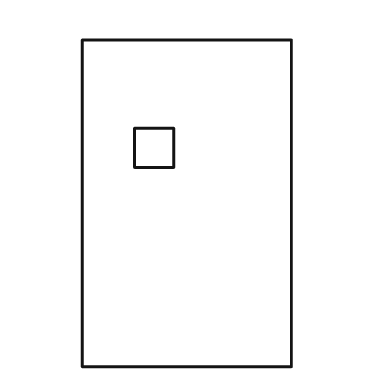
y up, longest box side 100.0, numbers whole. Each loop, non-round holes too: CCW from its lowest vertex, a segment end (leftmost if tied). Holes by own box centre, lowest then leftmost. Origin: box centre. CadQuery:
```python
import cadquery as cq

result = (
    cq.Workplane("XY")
    .moveTo(-32.0, -50.0)
    .lineTo(32.0, -50.0)
    .lineTo(32.0, 50.0)
    .lineTo(-32.0, 50.0)
    .close()
    .moveTo(-16.0, 11.0)
    .lineTo(-4.0, 11.0)
    .lineTo(-4.0, 23.0)
    .lineTo(-16.0, 23.0)
    .close()
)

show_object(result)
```